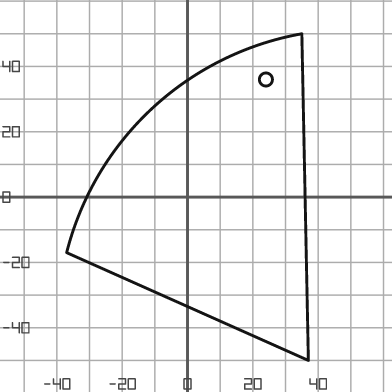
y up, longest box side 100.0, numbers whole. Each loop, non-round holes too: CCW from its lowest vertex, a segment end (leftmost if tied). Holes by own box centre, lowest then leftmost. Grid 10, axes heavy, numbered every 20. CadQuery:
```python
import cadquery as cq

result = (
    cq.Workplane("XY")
    .moveTo(37.0, -50.0)
    .lineTo(35.0, 50.0)
    .threePointArc((-11.0, 27.0), (-37.0, -17.0))
    .close()
    .moveTo(24.0, 36.0)
    .circle(2.0)
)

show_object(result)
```